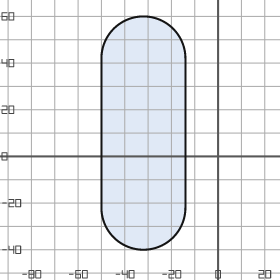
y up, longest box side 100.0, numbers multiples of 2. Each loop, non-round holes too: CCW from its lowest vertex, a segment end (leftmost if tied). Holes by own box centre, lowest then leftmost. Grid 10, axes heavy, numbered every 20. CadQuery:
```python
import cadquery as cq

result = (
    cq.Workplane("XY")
    .moveTo(-50.0, -22.0)
    .threePointArc((-32.0, -40.0), (-14.0, -22.0))
    .lineTo(-14.0, 42.0)
    .threePointArc((-32.0, 60.0), (-50.0, 42.0))
    .close()
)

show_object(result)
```